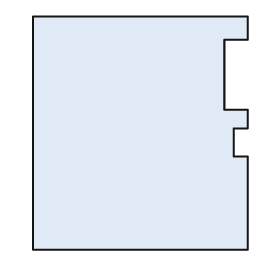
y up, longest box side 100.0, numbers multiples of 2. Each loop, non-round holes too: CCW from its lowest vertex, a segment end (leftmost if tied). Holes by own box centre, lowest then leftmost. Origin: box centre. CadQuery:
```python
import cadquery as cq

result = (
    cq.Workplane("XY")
    .moveTo(-46.0, -50.0)
    .lineTo(46.0, -50.0)
    .lineTo(46.0, -10.0)
    .lineTo(40.0, -10.0)
    .lineTo(40.0, 2.0)
    .lineTo(46.0, 2.0)
    .lineTo(46.0, 10.0)
    .lineTo(36.0, 10.0)
    .lineTo(36.0, 40.0)
    .lineTo(46.0, 40.0)
    .lineTo(46.0, 50.0)
    .lineTo(-46.0, 50.0)
    .close()
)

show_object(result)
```